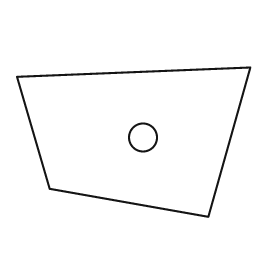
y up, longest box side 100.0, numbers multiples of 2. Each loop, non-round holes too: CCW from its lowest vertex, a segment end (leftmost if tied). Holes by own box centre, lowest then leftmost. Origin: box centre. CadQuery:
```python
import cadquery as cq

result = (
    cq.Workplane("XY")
    .moveTo(32.0, -32.0)
    .lineTo(50.0, 32.0)
    .lineTo(-50.0, 28.0)
    .lineTo(-36.0, -20.0)
    .close()
    .moveTo(4.0, 2.0)
    .circle(6.0)
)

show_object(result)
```